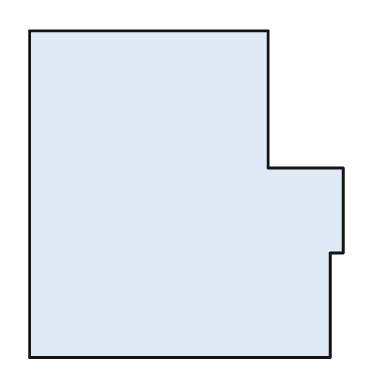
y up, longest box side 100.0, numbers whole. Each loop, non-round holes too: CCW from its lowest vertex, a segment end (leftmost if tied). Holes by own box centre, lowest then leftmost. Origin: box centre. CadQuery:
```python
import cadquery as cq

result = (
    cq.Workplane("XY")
    .moveTo(-48.0, -50.0)
    .lineTo(44.0, -50.0)
    .lineTo(44.0, -18.0)
    .lineTo(48.0, -18.0)
    .lineTo(48.0, 8.0)
    .lineTo(25.0, 8.0)
    .lineTo(25.0, 50.0)
    .lineTo(-48.0, 50.0)
    .close()
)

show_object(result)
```